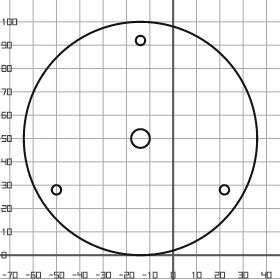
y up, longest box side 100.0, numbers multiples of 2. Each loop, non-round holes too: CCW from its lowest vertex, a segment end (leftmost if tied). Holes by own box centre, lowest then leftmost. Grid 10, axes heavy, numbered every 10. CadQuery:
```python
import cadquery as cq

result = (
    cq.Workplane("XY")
    .moveTo(-14.0, 50.0)
    .circle(50.0)
    .moveTo(-50.0, 28.0)
    .circle(2.0)
    .moveTo(22.0, 28.0)
    .circle(2.0)
    .moveTo(-14.0, 50.0)
    .circle(4.0)
    .moveTo(-14.0, 92.0)
    .circle(2.0)
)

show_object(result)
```